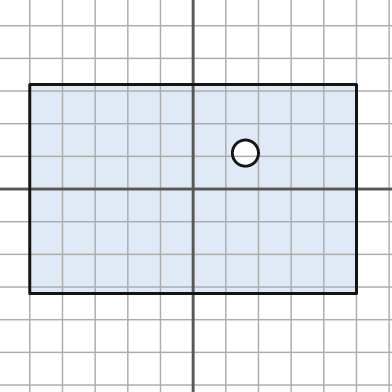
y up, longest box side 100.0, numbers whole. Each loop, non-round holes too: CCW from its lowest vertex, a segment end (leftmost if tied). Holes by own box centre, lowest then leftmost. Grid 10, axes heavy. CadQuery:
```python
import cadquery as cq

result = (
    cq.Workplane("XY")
    .moveTo(-50.0, -32.0)
    .lineTo(50.0, -32.0)
    .lineTo(50.0, 32.0)
    .lineTo(-50.0, 32.0)
    .close()
    .moveTo(16.0, 11.0)
    .circle(4.0)
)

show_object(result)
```